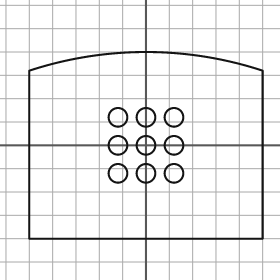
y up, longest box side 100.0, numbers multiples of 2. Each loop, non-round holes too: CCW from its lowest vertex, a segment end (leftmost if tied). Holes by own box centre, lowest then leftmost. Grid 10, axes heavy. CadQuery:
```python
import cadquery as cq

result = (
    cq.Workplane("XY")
    .moveTo(-50.0, -40.0)
    .lineTo(50.0, -40.0)
    .lineTo(50.0, 32.0)
    .threePointArc((0.0, 40.0), (-50.0, 32.0))
    .close()
    .moveTo(-12.0, -12.0)
    .circle(4.0)
    .moveTo(0.0, -12.0)
    .circle(4.0)
    .moveTo(12.0, -12.0)
    .circle(4.0)
    .moveTo(-12.0, 0.0)
    .circle(4.0)
    .moveTo(0.0, 0.0)
    .circle(4.0)
    .moveTo(12.0, 0.0)
    .circle(4.0)
    .moveTo(-12.0, 12.0)
    .circle(4.0)
    .moveTo(0.0, 12.0)
    .circle(4.0)
    .moveTo(12.0, 12.0)
    .circle(4.0)
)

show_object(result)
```